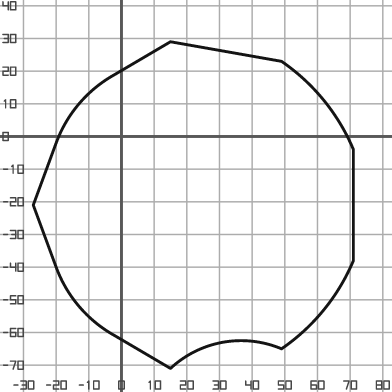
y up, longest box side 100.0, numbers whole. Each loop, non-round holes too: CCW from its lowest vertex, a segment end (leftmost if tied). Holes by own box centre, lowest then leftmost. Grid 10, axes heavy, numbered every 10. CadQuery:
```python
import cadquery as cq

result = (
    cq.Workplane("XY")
    .moveTo(15.0, -71.0)
    .threePointArc((31.0, -63.0), (49.0, -65.0))
    .threePointArc((62.0, -53.0), (71.0, -38.0))
    .lineTo(71.0, -4.0)
    .threePointArc((62.0, 11.0), (49.0, 23.0))
    .lineTo(15.0, 29.0)
    .lineTo(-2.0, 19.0)
    .threePointArc((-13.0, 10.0), (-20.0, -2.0))
    .lineTo(-27.0, -21.0)
    .lineTo(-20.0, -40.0)
    .threePointArc((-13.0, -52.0), (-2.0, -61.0))
    .close()
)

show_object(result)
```